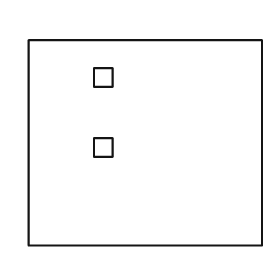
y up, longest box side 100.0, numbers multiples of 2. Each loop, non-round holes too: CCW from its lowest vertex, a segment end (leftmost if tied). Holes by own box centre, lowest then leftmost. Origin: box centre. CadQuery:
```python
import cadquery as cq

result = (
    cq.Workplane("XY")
    .moveTo(-50.0, -44.0)
    .lineTo(50.0, -44.0)
    .lineTo(50.0, 44.0)
    .lineTo(-50.0, 44.0)
    .close()
    .moveTo(-22.0, -6.0)
    .lineTo(-14.0, -6.0)
    .lineTo(-14.0, 2.0)
    .lineTo(-22.0, 2.0)
    .close()
    .moveTo(-22.0, 24.0)
    .lineTo(-14.0, 24.0)
    .lineTo(-14.0, 32.0)
    .lineTo(-22.0, 32.0)
    .close()
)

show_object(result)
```